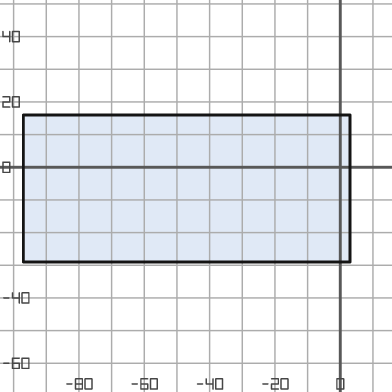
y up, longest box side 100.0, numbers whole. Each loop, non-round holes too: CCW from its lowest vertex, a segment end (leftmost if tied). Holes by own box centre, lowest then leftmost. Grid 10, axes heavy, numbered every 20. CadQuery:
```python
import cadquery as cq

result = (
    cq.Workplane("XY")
    .moveTo(-97.0, -29.0)
    .lineTo(3.0, -29.0)
    .lineTo(3.0, 16.0)
    .lineTo(-97.0, 16.0)
    .close()
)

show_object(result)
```